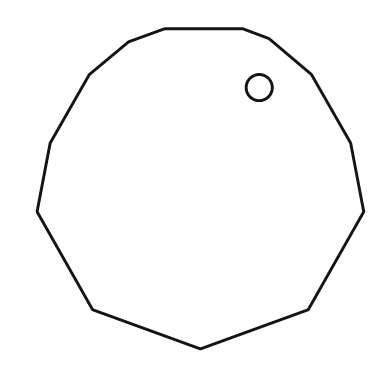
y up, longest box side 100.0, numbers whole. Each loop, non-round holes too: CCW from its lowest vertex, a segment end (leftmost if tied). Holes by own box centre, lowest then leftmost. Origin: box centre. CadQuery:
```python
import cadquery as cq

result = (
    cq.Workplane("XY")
    .moveTo(0.0, -49.0)
    .lineTo(33.0, -37.0)
    .lineTo(50.0, -7.0)
    .lineTo(46.0, 14.0)
    .lineTo(34.0, 35.0)
    .lineTo(21.0, 46.0)
    .lineTo(13.0, 49.0)
    .lineTo(-11.0, 49.0)
    .lineTo(-22.0, 45.0)
    .lineTo(-34.0, 35.0)
    .lineTo(-46.0, 14.0)
    .lineTo(-50.0, -7.0)
    .lineTo(-33.0, -37.0)
    .close()
    .moveTo(18.0, 31.0)
    .circle(4.0)
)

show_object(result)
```